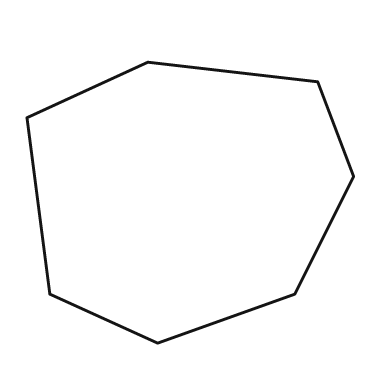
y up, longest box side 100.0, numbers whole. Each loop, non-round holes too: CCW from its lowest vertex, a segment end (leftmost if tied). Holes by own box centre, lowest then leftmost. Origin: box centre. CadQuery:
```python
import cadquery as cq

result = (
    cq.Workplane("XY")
    .moveTo(-10.0, -43.0)
    .lineTo(32.0, -28.0)
    .lineTo(50.0, 8.0)
    .lineTo(39.0, 37.0)
    .lineTo(-13.0, 43.0)
    .lineTo(-50.0, 26.0)
    .lineTo(-43.0, -28.0)
    .close()
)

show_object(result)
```